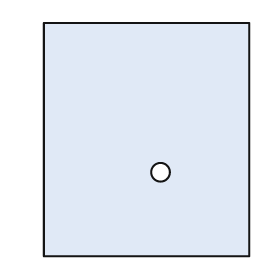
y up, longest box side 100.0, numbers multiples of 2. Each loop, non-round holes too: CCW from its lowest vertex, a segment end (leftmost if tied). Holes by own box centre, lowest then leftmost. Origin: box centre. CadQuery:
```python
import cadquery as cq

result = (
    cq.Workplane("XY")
    .moveTo(-44.0, -50.0)
    .lineTo(44.0, -50.0)
    .lineTo(44.0, 50.0)
    .lineTo(-44.0, 50.0)
    .close()
    .moveTo(6.0, -14.0)
    .circle(4.0)
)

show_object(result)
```